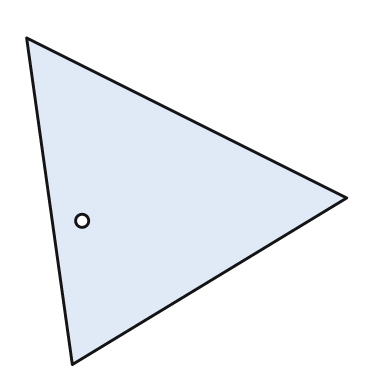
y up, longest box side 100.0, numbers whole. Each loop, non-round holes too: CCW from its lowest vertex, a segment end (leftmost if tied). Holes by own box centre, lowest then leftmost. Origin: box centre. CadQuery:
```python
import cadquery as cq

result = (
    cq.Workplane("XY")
    .moveTo(-35.0, -50.0)
    .lineTo(49.0, 1.0)
    .lineTo(-49.0, 50.0)
    .close()
    .moveTo(-32.0, -6.0)
    .circle(2.0)
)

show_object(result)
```